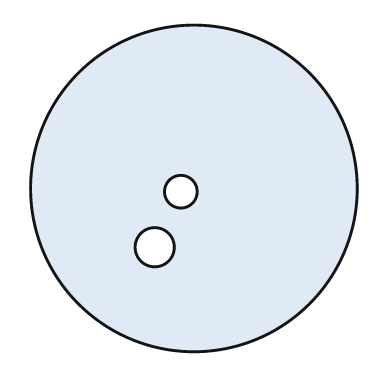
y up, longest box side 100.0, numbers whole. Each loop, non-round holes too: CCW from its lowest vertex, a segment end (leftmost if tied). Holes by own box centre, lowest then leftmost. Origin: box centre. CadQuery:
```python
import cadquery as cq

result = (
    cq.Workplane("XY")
    .moveTo(0.0, 0.0)
    .circle(50.0)
    .moveTo(-12.0, -18.0)
    .circle(6.0)
    .moveTo(-4.0, -1.0)
    .circle(5.0)
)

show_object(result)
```